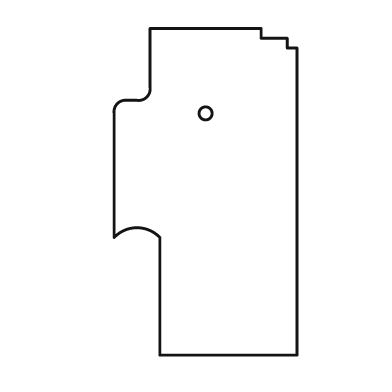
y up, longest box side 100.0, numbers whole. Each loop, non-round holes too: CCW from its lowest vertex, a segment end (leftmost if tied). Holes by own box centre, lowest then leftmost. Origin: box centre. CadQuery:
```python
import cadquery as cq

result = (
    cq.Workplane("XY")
    .moveTo(-14.0, -50.0)
    .lineTo(28.0, -50.0)
    .lineTo(28.0, 44.0)
    .lineTo(25.0, 44.0)
    .lineTo(25.0, 47.0)
    .lineTo(17.0, 47.0)
    .lineTo(17.0, 50.0)
    .lineTo(-17.0, 50.0)
    .lineTo(-17.0, 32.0)
    .threePointArc((-18.0, 29.0), (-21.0, 28.0))
    .lineTo(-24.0, 28.0)
    .threePointArc((-27.0, 27.0), (-28.0, 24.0))
    .lineTo(-28.0, -14.0)
    .threePointArc((-21.0, -11.0), (-14.0, -14.0))
    .close()
    .moveTo(0.0, 24.0)
    .circle(2.0)
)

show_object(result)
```